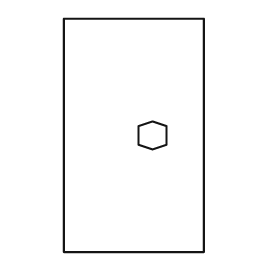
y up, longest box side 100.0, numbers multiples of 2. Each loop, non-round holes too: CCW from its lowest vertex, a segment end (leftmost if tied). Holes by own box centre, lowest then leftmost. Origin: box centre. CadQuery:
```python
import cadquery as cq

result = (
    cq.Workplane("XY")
    .moveTo(-30.0, -50.0)
    .lineTo(30.0, -50.0)
    .lineTo(30.0, 50.0)
    .lineTo(-30.0, 50.0)
    .close()
    .moveTo(8.0, -6.0)
    .lineTo(14.0, -4.0)
    .lineTo(14.0, 4.0)
    .lineTo(8.0, 6.0)
    .lineTo(2.0, 4.0)
    .lineTo(2.0, -4.0)
    .close()
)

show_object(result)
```